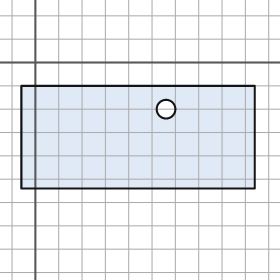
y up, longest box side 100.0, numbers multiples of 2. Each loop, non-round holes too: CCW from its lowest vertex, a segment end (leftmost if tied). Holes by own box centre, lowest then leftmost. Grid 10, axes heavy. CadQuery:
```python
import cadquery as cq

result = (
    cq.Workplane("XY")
    .moveTo(-6.0, -54.0)
    .lineTo(94.0, -54.0)
    .lineTo(94.0, -10.0)
    .lineTo(-6.0, -10.0)
    .close()
    .moveTo(56.0, -20.0)
    .circle(4.0)
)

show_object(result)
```